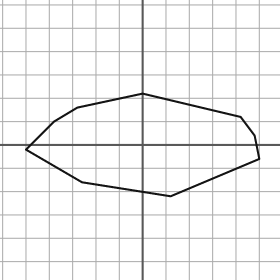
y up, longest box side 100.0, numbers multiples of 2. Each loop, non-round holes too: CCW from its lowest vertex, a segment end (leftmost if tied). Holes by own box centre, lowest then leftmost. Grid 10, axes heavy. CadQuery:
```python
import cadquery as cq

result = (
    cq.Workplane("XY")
    .moveTo(12.0, -22.0)
    .lineTo(50.0, -6.0)
    .lineTo(48.0, 4.0)
    .lineTo(42.0, 12.0)
    .lineTo(0.0, 22.0)
    .lineTo(-28.0, 16.0)
    .lineTo(-38.0, 10.0)
    .lineTo(-50.0, -2.0)
    .lineTo(-26.0, -16.0)
    .close()
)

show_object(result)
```